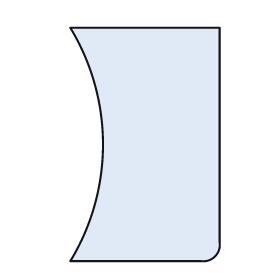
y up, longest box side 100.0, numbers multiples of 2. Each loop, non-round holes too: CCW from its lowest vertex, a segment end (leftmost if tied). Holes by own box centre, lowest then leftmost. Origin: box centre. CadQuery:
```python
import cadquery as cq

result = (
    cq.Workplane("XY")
    .moveTo(-32.0, -50.0)
    .lineTo(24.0, -50.0)
    .threePointArc((30.0, -48.0), (32.0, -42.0))
    .lineTo(32.0, 50.0)
    .lineTo(-32.0, 50.0)
    .threePointArc((-18.0, 0.0), (-32.0, -50.0))
    .close()
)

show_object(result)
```